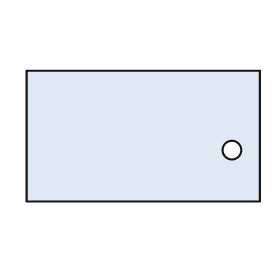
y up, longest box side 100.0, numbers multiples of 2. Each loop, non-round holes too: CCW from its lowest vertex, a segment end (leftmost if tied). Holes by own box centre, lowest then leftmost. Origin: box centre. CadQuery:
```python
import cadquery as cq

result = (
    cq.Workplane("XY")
    .moveTo(-50.0, -28.0)
    .lineTo(50.0, -28.0)
    .lineTo(50.0, 28.0)
    .lineTo(-50.0, 28.0)
    .close()
    .moveTo(38.0, -6.0)
    .circle(4.0)
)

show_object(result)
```